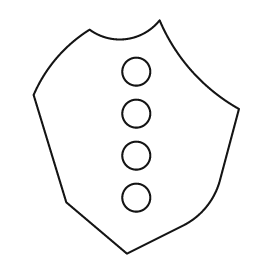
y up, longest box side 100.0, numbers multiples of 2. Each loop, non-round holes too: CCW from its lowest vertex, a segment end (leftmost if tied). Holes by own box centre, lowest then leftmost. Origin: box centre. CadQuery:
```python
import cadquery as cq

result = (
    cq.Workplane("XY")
    .moveTo(-4.0, -50.0)
    .lineTo(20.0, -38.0)
    .threePointArc((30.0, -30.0), (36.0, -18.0))
    .lineTo(44.0, 12.0)
    .threePointArc((24.0, 28.0), (10.0, 50.0))
    .threePointArc((-4.0, 42.0), (-20.0, 46.0))
    .threePointArc((-34.0, 34.0), (-44.0, 18.0))
    .lineTo(-30.0, -28.0)
    .close()
    .moveTo(0.0, -26.0)
    .circle(6.0)
    .moveTo(0.0, -8.0)
    .circle(6.0)
    .moveTo(0.0, 10.0)
    .circle(6.0)
    .moveTo(0.0, 28.0)
    .circle(6.0)
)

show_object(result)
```